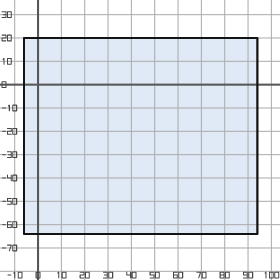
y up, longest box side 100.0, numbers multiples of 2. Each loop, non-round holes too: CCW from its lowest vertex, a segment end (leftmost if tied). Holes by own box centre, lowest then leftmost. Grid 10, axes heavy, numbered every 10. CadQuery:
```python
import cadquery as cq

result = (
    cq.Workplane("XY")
    .moveTo(-6.0, -64.0)
    .lineTo(94.0, -64.0)
    .lineTo(94.0, 20.0)
    .lineTo(-6.0, 20.0)
    .close()
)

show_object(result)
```